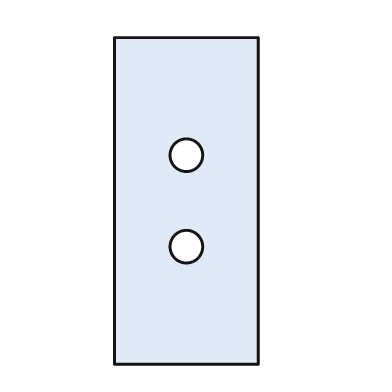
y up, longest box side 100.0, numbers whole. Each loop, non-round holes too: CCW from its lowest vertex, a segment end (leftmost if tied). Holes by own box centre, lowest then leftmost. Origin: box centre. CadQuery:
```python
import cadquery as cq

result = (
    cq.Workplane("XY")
    .moveTo(-22.0, -50.0)
    .lineTo(22.0, -50.0)
    .lineTo(22.0, 50.0)
    .lineTo(-22.0, 50.0)
    .close()
    .moveTo(0.0, -14.0)
    .circle(5.0)
    .moveTo(0.0, 14.0)
    .circle(5.0)
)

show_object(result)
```